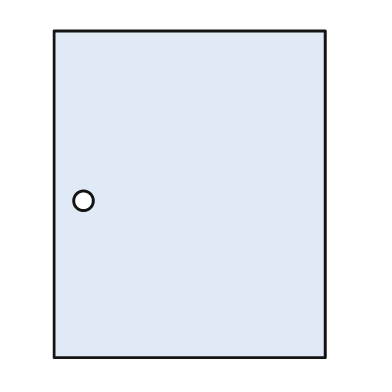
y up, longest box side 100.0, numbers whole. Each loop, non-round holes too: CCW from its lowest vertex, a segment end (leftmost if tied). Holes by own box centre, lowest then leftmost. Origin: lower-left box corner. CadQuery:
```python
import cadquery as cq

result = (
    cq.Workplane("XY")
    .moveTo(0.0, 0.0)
    .lineTo(83.0, 0.0)
    .lineTo(83.0, 100.0)
    .lineTo(0.0, 100.0)
    .close()
    .moveTo(9.0, 48.0)
    .circle(3.0)
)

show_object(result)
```